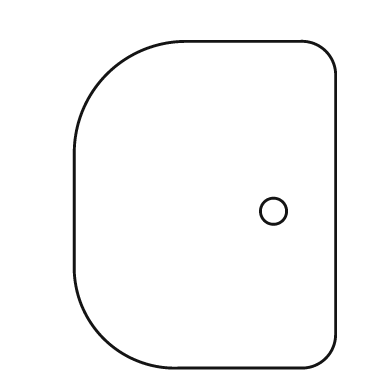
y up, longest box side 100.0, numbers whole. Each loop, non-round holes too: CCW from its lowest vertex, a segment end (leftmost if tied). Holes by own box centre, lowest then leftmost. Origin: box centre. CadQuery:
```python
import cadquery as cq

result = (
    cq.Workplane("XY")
    .moveTo(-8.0, -50.0)
    .lineTo(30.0, -50.0)
    .threePointArc((37.0, -47.0), (40.0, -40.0))
    .lineTo(40.0, 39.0)
    .threePointArc((37.0, 47.0), (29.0, 50.0))
    .lineTo(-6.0, 50.0)
    .threePointArc((-30.0, 40.0), (-40.0, 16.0))
    .lineTo(-40.0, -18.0)
    .threePointArc((-31.0, -41.0), (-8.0, -50.0))
    .close()
    .moveTo(21.0, -2.0)
    .circle(4.0)
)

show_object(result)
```